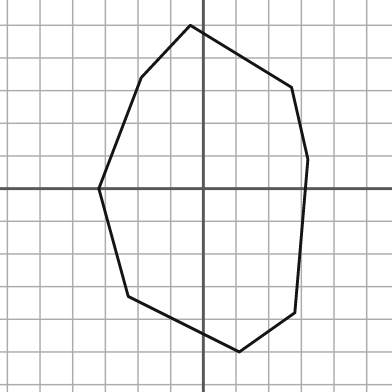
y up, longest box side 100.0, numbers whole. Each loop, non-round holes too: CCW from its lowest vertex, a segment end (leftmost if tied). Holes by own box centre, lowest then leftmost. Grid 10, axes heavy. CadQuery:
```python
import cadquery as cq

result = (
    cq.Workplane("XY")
    .moveTo(11.0, -50.0)
    .lineTo(28.0, -38.0)
    .lineTo(32.0, 9.0)
    .lineTo(27.0, 31.0)
    .lineTo(-4.0, 50.0)
    .lineTo(-19.0, 34.0)
    .lineTo(-32.0, 0.0)
    .lineTo(-23.0, -33.0)
    .close()
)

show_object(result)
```